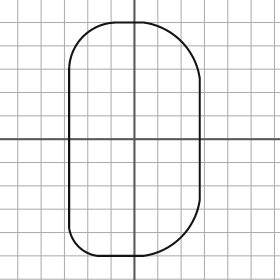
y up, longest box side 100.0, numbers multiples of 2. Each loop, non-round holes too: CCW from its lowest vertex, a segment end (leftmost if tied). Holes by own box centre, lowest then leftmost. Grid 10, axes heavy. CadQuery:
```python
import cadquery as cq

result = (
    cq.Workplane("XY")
    .moveTo(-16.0, -50.0)
    .lineTo(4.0, -50.0)
    .threePointArc((20.0, -42.0), (28.0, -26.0))
    .lineTo(28.0, 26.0)
    .threePointArc((20.0, 42.0), (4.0, 50.0))
    .lineTo(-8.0, 50.0)
    .threePointArc((-22.0, 44.0), (-28.0, 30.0))
    .lineTo(-28.0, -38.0)
    .threePointArc((-24.0, -46.0), (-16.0, -50.0))
    .close()
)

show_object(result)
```